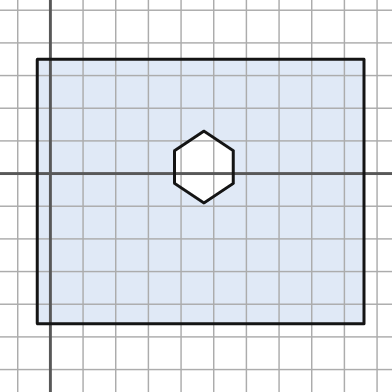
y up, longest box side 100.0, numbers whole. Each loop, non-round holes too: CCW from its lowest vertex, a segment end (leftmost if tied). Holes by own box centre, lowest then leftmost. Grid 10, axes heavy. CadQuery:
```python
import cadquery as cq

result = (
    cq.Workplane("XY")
    .moveTo(-4.0, -46.0)
    .lineTo(96.0, -46.0)
    .lineTo(96.0, 35.0)
    .lineTo(-4.0, 35.0)
    .close()
    .moveTo(47.0, -9.0)
    .lineTo(56.0, -3.0)
    .lineTo(56.0, 7.0)
    .lineTo(47.0, 13.0)
    .lineTo(38.0, 7.0)
    .lineTo(38.0, -3.0)
    .close()
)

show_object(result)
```